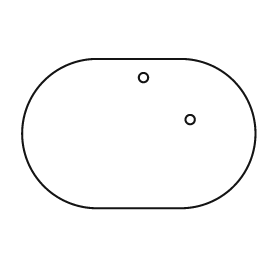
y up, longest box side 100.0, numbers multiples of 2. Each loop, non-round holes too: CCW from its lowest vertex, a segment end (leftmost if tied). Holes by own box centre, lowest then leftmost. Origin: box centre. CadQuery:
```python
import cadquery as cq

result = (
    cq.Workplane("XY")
    .moveTo(-18.0, -32.0)
    .lineTo(18.0, -32.0)
    .threePointArc((50.0, 0.0), (18.0, 32.0))
    .lineTo(-18.0, 32.0)
    .threePointArc((-50.0, 0.0), (-18.0, -32.0))
    .close()
    .moveTo(22.0, 6.0)
    .circle(2.0)
    .moveTo(2.0, 24.0)
    .circle(2.0)
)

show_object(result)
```